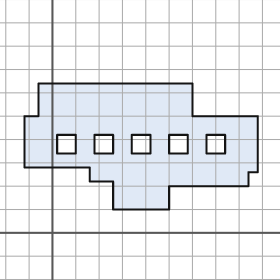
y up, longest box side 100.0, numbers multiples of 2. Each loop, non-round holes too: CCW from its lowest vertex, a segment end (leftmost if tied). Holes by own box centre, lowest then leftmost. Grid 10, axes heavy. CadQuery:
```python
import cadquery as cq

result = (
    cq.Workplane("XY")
    .moveTo(26.0, 10.0)
    .lineTo(50.0, 10.0)
    .lineTo(50.0, 20.0)
    .lineTo(84.0, 20.0)
    .lineTo(84.0, 26.0)
    .lineTo(88.0, 26.0)
    .lineTo(88.0, 50.0)
    .lineTo(60.0, 50.0)
    .lineTo(60.0, 64.0)
    .lineTo(-6.0, 64.0)
    .lineTo(-6.0, 50.0)
    .lineTo(-12.0, 50.0)
    .lineTo(-12.0, 28.0)
    .lineTo(16.0, 28.0)
    .lineTo(16.0, 22.0)
    .lineTo(26.0, 22.0)
    .close()
    .moveTo(2.0, 34.0)
    .lineTo(10.0, 34.0)
    .lineTo(10.0, 42.0)
    .lineTo(2.0, 42.0)
    .close()
    .moveTo(18.0, 34.0)
    .lineTo(26.0, 34.0)
    .lineTo(26.0, 42.0)
    .lineTo(18.0, 42.0)
    .close()
    .moveTo(34.0, 34.0)
    .lineTo(42.0, 34.0)
    .lineTo(42.0, 42.0)
    .lineTo(34.0, 42.0)
    .close()
    .moveTo(50.0, 34.0)
    .lineTo(58.0, 34.0)
    .lineTo(58.0, 42.0)
    .lineTo(50.0, 42.0)
    .close()
    .moveTo(66.0, 34.0)
    .lineTo(74.0, 34.0)
    .lineTo(74.0, 42.0)
    .lineTo(66.0, 42.0)
    .close()
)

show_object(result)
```